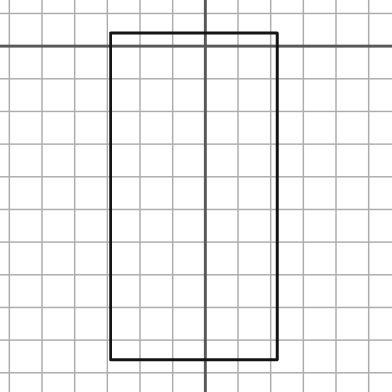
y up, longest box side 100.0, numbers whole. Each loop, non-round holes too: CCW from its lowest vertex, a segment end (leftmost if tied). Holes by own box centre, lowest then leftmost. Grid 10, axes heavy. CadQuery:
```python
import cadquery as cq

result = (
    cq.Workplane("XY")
    .moveTo(-29.0, -96.0)
    .lineTo(22.0, -96.0)
    .lineTo(22.0, 4.0)
    .lineTo(-29.0, 4.0)
    .close()
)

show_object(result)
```